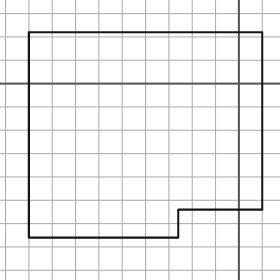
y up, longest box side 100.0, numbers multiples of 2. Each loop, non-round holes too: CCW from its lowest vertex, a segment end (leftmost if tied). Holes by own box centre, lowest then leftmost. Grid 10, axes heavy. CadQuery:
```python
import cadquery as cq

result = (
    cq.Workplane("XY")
    .moveTo(-90.0, -66.0)
    .lineTo(-26.0, -66.0)
    .lineTo(-26.0, -54.0)
    .lineTo(10.0, -54.0)
    .lineTo(10.0, 22.0)
    .lineTo(-90.0, 22.0)
    .close()
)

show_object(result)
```